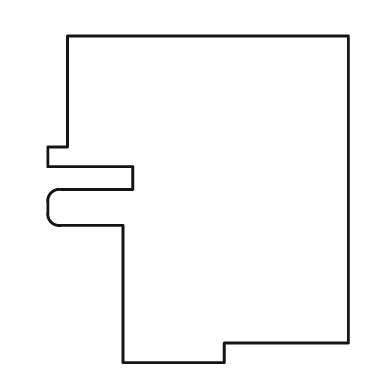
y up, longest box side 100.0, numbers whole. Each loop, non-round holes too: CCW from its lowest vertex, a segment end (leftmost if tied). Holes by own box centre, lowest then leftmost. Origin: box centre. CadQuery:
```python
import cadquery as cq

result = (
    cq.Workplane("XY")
    .moveTo(-23.0, -50.0)
    .lineTo(8.0, -50.0)
    .lineTo(8.0, -44.0)
    .lineTo(46.0, -44.0)
    .lineTo(46.0, 50.0)
    .lineTo(-40.0, 50.0)
    .lineTo(-40.0, 16.0)
    .lineTo(-46.0, 16.0)
    .lineTo(-46.0, 10.0)
    .lineTo(-20.0, 10.0)
    .lineTo(-20.0, 3.0)
    .lineTo(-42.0, 3.0)
    .threePointArc((-45.0, 2.0), (-46.0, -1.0))
    .lineTo(-46.0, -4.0)
    .threePointArc((-45.0, -7.0), (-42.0, -8.0))
    .lineTo(-23.0, -8.0)
    .close()
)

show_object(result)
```